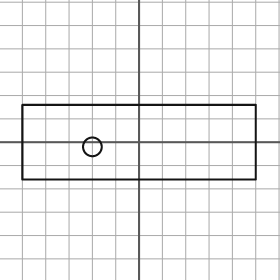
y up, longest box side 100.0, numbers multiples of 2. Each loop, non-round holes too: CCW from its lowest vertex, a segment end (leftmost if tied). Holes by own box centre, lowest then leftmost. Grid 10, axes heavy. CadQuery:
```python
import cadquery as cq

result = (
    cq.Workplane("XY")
    .moveTo(-50.0, -16.0)
    .lineTo(50.0, -16.0)
    .lineTo(50.0, 16.0)
    .lineTo(-50.0, 16.0)
    .close()
    .moveTo(-20.0, -2.0)
    .circle(4.0)
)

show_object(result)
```